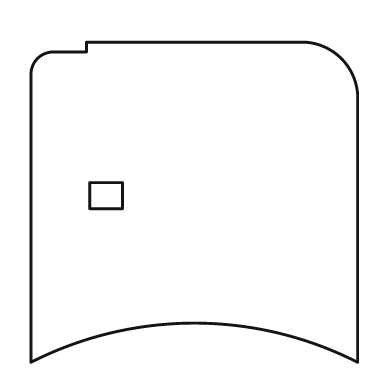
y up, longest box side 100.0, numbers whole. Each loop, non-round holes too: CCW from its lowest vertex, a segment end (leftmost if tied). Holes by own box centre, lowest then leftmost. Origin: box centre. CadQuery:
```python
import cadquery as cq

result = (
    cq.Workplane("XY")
    .moveTo(-50.0, -49.0)
    .threePointArc((0.0, -37.0), (50.0, -49.0))
    .lineTo(50.0, 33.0)
    .threePointArc((45.0, 44.0), (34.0, 49.0))
    .lineTo(-33.0, 49.0)
    .lineTo(-33.0, 46.0)
    .lineTo(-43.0, 46.0)
    .threePointArc((-48.0, 44.0), (-50.0, 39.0))
    .close()
    .moveTo(-32.0, -2.0)
    .lineTo(-22.0, -2.0)
    .lineTo(-22.0, 6.0)
    .lineTo(-32.0, 6.0)
    .close()
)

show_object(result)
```